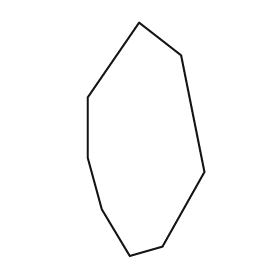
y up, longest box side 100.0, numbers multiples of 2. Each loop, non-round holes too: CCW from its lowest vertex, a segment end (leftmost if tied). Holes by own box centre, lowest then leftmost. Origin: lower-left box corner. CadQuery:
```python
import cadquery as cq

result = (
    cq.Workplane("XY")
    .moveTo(18.0, 0.0)
    .lineTo(32.0, 4.0)
    .lineTo(50.0, 36.0)
    .lineTo(40.0, 86.0)
    .lineTo(22.0, 100.0)
    .lineTo(0.0, 68.0)
    .lineTo(0.0, 42.0)
    .lineTo(6.0, 20.0)
    .close()
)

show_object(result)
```